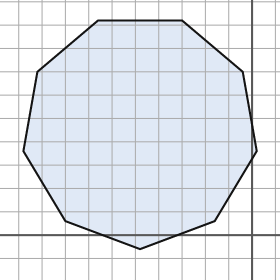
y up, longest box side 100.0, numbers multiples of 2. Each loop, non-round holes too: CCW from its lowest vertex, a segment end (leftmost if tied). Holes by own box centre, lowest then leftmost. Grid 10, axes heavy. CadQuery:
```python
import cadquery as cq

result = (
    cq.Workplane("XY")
    .moveTo(-48.0, -6.0)
    .lineTo(-16.0, 6.0)
    .lineTo(2.0, 36.0)
    .lineTo(-4.0, 70.0)
    .lineTo(-30.0, 92.0)
    .lineTo(-66.0, 92.0)
    .lineTo(-92.0, 70.0)
    .lineTo(-98.0, 36.0)
    .lineTo(-80.0, 6.0)
    .close()
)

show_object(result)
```